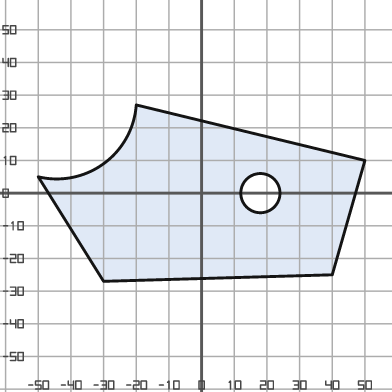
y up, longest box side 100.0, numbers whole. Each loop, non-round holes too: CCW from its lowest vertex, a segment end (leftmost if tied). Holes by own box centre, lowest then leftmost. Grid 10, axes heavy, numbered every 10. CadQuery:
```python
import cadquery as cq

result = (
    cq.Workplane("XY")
    .moveTo(-30.0, -27.0)
    .lineTo(40.0, -25.0)
    .lineTo(50.0, 10.0)
    .lineTo(-20.0, 27.0)
    .threePointArc((-30.0, 9.0), (-50.0, 5.0))
    .close()
    .moveTo(18.0, 0.0)
    .circle(6.0)
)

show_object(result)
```